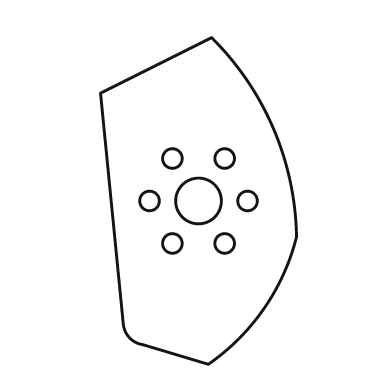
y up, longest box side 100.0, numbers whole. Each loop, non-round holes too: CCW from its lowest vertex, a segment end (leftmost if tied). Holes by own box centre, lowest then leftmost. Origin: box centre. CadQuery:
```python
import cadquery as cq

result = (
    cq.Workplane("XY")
    .moveTo(3.0, -50.0)
    .threePointArc((20.0, -33.0), (30.0, -11.0))
    .threePointArc((23.0, 22.0), (4.0, 50.0))
    .lineTo(-30.0, 33.0)
    .lineTo(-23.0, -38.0)
    .threePointArc((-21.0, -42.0), (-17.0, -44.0))
    .close()
    .moveTo(-8.0, -13.0)
    .circle(3.0)
    .moveTo(8.0, -13.0)
    .circle(3.0)
    .moveTo(-15.0, 0.0)
    .circle(3.0)
    .moveTo(0.0, 0.0)
    .circle(7.0)
    .moveTo(15.0, 0.0)
    .circle(3.0)
    .moveTo(-8.0, 13.0)
    .circle(3.0)
    .moveTo(8.0, 13.0)
    .circle(3.0)
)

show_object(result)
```